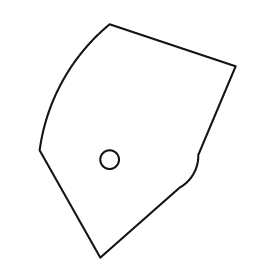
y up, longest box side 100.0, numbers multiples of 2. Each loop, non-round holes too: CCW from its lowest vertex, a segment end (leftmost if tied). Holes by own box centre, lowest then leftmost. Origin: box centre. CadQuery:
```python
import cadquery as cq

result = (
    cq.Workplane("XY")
    .moveTo(-16.0, -50.0)
    .lineTo(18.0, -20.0)
    .threePointArc((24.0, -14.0), (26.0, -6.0))
    .lineTo(42.0, 32.0)
    .lineTo(-12.0, 50.0)
    .threePointArc((-32.0, 26.0), (-42.0, -4.0))
    .close()
    .moveTo(-12.0, -8.0)
    .circle(4.0)
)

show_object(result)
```